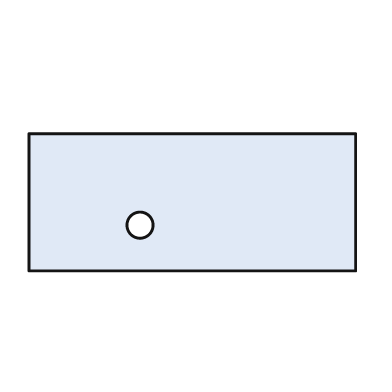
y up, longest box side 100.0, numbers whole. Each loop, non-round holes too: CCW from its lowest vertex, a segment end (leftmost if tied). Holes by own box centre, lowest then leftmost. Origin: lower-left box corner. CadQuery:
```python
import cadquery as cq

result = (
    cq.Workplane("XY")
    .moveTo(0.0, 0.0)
    .lineTo(100.0, 0.0)
    .lineTo(100.0, 42.0)
    .lineTo(0.0, 42.0)
    .close()
    .moveTo(34.0, 14.0)
    .circle(4.0)
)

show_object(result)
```